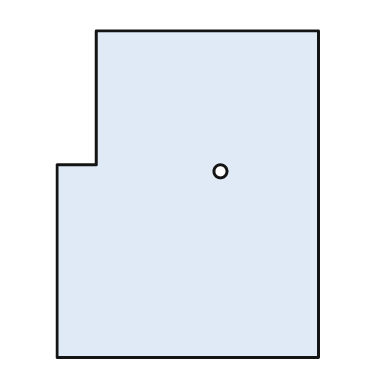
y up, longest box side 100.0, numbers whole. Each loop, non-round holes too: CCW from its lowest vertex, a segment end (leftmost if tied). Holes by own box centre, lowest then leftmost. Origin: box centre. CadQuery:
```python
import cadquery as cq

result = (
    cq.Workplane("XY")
    .moveTo(-40.0, -50.0)
    .lineTo(40.0, -50.0)
    .lineTo(40.0, 50.0)
    .lineTo(-28.0, 50.0)
    .lineTo(-28.0, 9.0)
    .lineTo(-40.0, 9.0)
    .close()
    .moveTo(10.0, 7.0)
    .circle(2.0)
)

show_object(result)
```